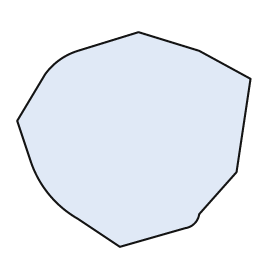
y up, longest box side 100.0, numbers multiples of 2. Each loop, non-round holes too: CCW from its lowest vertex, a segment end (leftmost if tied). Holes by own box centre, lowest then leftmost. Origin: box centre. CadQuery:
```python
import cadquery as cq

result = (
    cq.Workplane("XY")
    .moveTo(-6.0, -46.0)
    .lineTo(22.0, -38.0)
    .threePointArc((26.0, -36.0), (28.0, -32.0))
    .lineTo(44.0, -14.0)
    .lineTo(50.0, 26.0)
    .lineTo(28.0, 38.0)
    .lineTo(2.0, 46.0)
    .lineTo(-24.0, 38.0)
    .threePointArc((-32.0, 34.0), (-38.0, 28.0))
    .lineTo(-50.0, 8.0)
    .lineTo(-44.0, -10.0)
    .threePointArc((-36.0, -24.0), (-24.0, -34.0))
    .close()
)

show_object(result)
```